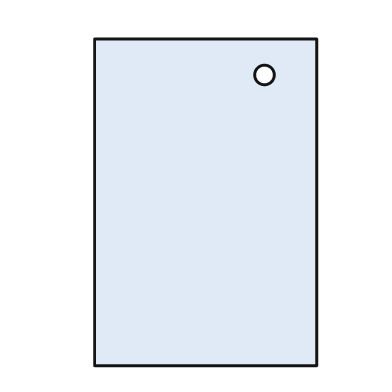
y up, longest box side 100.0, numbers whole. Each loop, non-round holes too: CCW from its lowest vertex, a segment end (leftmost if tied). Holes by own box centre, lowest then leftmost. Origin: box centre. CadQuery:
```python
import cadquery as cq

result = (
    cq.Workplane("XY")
    .moveTo(-34.0, -50.0)
    .lineTo(34.0, -50.0)
    .lineTo(34.0, 50.0)
    .lineTo(-34.0, 50.0)
    .close()
    .moveTo(18.0, 39.0)
    .circle(3.0)
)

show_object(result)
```